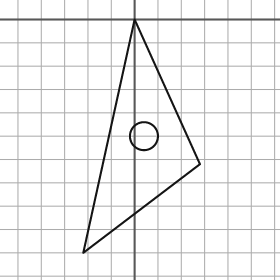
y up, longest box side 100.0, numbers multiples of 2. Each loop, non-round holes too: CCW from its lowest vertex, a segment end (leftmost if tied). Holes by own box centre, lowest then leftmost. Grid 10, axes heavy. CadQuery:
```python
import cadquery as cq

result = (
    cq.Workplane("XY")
    .moveTo(-22.0, -100.0)
    .lineTo(28.0, -62.0)
    .lineTo(0.0, 0.0)
    .close()
    .moveTo(4.0, -50.0)
    .circle(6.0)
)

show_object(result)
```